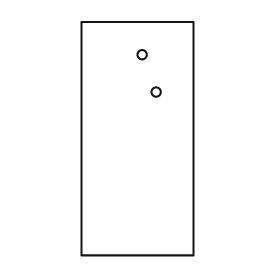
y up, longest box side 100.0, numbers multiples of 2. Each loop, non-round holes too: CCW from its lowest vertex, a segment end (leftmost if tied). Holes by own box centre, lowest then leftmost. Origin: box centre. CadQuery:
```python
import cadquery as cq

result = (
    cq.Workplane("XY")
    .moveTo(-24.0, -50.0)
    .lineTo(24.0, -50.0)
    .lineTo(24.0, 50.0)
    .lineTo(-24.0, 50.0)
    .close()
    .moveTo(8.0, 20.0)
    .circle(2.0)
    .moveTo(2.0, 36.0)
    .circle(2.0)
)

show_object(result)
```